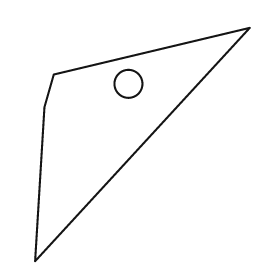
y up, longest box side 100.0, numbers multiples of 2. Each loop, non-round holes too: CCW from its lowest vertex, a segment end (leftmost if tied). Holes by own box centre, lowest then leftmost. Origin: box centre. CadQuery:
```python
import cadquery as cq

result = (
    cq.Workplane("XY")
    .moveTo(-46.0, -50.0)
    .lineTo(46.0, 50.0)
    .lineTo(-38.0, 30.0)
    .lineTo(-42.0, 16.0)
    .close()
    .moveTo(-6.0, 26.0)
    .circle(6.0)
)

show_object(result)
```